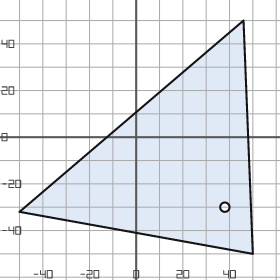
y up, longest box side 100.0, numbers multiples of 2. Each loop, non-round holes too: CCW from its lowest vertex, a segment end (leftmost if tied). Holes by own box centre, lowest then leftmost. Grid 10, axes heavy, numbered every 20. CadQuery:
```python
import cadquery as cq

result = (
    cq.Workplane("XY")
    .moveTo(50.0, -50.0)
    .lineTo(46.0, 50.0)
    .lineTo(-50.0, -32.0)
    .close()
    .moveTo(38.0, -30.0)
    .circle(2.0)
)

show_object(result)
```